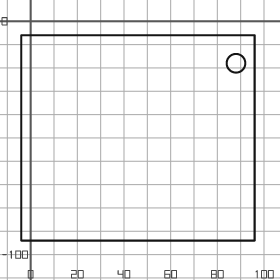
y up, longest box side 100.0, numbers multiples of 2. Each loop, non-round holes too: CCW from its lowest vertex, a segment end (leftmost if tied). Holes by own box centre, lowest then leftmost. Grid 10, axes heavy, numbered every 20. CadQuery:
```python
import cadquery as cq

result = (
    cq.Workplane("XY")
    .moveTo(-4.0, -94.0)
    .lineTo(96.0, -94.0)
    .lineTo(96.0, -6.0)
    .lineTo(-4.0, -6.0)
    .close()
    .moveTo(88.0, -18.0)
    .circle(4.0)
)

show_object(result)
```